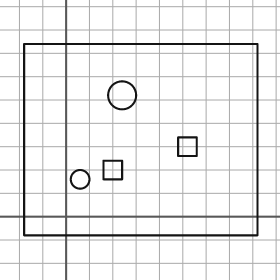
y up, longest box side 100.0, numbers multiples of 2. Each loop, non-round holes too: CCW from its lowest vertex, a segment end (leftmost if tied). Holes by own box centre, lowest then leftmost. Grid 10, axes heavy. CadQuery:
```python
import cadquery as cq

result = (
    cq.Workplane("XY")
    .moveTo(-18.0, -8.0)
    .lineTo(82.0, -8.0)
    .lineTo(82.0, 74.0)
    .lineTo(-18.0, 74.0)
    .close()
    .moveTo(6.0, 16.0)
    .circle(4.0)
    .moveTo(16.0, 16.0)
    .lineTo(24.0, 16.0)
    .lineTo(24.0, 24.0)
    .lineTo(16.0, 24.0)
    .close()
    .moveTo(48.0, 26.0)
    .lineTo(56.0, 26.0)
    .lineTo(56.0, 34.0)
    .lineTo(48.0, 34.0)
    .close()
    .moveTo(24.0, 52.0)
    .circle(6.0)
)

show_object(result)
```